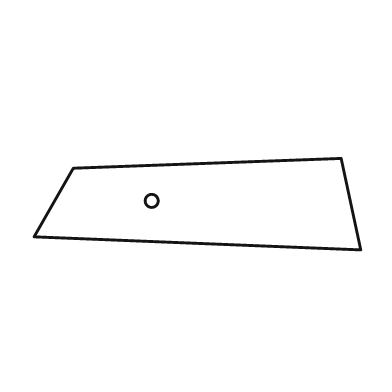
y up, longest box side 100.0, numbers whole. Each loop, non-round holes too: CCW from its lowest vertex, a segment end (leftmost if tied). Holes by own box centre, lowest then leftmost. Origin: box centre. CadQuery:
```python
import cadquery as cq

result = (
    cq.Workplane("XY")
    .moveTo(50.0, -14.0)
    .lineTo(44.0, 14.0)
    .lineTo(-38.0, 11.0)
    .lineTo(-50.0, -10.0)
    .close()
    .moveTo(-14.0, 1.0)
    .circle(2.0)
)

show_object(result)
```